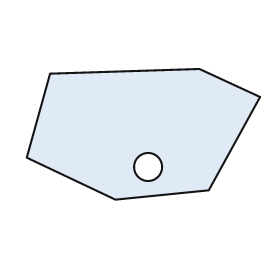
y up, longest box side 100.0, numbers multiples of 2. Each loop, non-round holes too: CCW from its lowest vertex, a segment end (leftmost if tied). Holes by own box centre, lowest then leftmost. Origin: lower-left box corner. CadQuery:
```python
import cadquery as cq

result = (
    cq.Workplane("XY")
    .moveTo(38.0, 0.0)
    .lineTo(78.0, 4.0)
    .lineTo(100.0, 44.0)
    .lineTo(74.0, 56.0)
    .lineTo(10.0, 54.0)
    .lineTo(0.0, 18.0)
    .close()
    .moveTo(52.0, 14.0)
    .circle(6.0)
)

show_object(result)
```